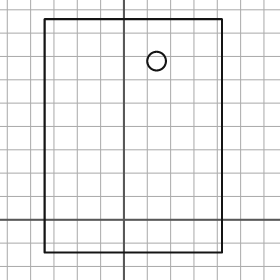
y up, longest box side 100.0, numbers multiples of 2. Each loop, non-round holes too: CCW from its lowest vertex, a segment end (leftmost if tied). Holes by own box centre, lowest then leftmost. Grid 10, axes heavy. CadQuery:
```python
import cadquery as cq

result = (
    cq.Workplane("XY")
    .moveTo(-34.0, -14.0)
    .lineTo(42.0, -14.0)
    .lineTo(42.0, 86.0)
    .lineTo(-34.0, 86.0)
    .close()
    .moveTo(14.0, 68.0)
    .circle(4.0)
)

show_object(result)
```